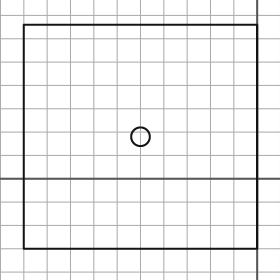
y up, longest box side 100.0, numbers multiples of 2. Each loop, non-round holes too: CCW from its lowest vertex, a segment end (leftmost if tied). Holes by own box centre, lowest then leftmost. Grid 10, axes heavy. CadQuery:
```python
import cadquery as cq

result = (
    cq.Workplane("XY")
    .moveTo(-100.0, -30.0)
    .lineTo(0.0, -30.0)
    .lineTo(0.0, 66.0)
    .lineTo(-100.0, 66.0)
    .close()
    .moveTo(-50.0, 18.0)
    .circle(4.0)
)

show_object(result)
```